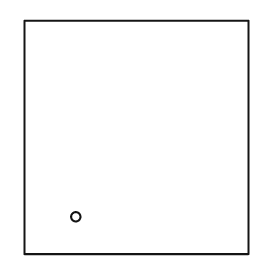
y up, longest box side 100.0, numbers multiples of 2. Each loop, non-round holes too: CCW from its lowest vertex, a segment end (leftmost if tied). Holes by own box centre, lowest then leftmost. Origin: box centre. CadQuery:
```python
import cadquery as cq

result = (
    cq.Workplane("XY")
    .moveTo(-48.0, -50.0)
    .lineTo(48.0, -50.0)
    .lineTo(48.0, 50.0)
    .lineTo(-48.0, 50.0)
    .close()
    .moveTo(-26.0, -34.0)
    .circle(2.0)
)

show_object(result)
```